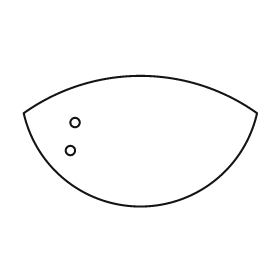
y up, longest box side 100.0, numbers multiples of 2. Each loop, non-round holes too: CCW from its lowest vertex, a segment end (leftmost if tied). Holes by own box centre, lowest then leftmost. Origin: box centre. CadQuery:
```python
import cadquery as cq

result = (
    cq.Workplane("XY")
    .moveTo(-50.0, 12.0)
    .threePointArc((0.0, -28.0), (50.0, 12.0))
    .threePointArc((0.0, 28.0), (-50.0, 12.0))
    .close()
    .moveTo(-30.0, -4.0)
    .circle(2.0)
    .moveTo(-28.0, 8.0)
    .circle(2.0)
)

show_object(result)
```